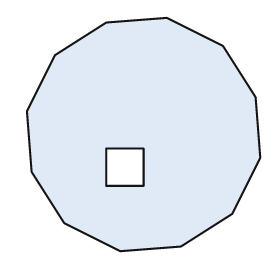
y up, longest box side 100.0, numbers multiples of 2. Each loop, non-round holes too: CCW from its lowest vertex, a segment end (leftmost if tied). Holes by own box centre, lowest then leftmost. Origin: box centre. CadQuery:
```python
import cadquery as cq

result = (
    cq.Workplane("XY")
    .moveTo(-10.0, -50.0)
    .lineTo(16.0, -48.0)
    .lineTo(38.0, -34.0)
    .lineTo(50.0, -10.0)
    .lineTo(48.0, 16.0)
    .lineTo(34.0, 38.0)
    .lineTo(10.0, 50.0)
    .lineTo(-16.0, 48.0)
    .lineTo(-38.0, 34.0)
    .lineTo(-50.0, 10.0)
    .lineTo(-48.0, -16.0)
    .lineTo(-34.0, -38.0)
    .close()
    .moveTo(-16.0, -22.0)
    .lineTo(0.0, -22.0)
    .lineTo(0.0, -6.0)
    .lineTo(-16.0, -6.0)
    .close()
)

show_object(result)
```